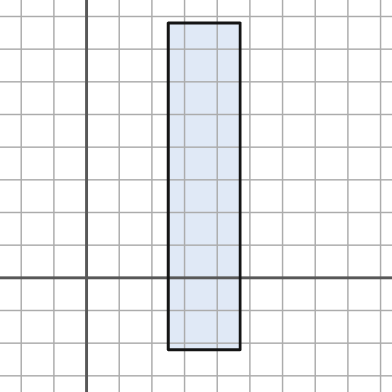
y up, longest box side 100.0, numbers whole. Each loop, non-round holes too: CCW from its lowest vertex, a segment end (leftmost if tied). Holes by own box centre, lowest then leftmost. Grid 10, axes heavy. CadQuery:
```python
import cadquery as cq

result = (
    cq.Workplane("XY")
    .moveTo(25.0, -22.0)
    .lineTo(47.0, -22.0)
    .lineTo(47.0, 78.0)
    .lineTo(25.0, 78.0)
    .close()
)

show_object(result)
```